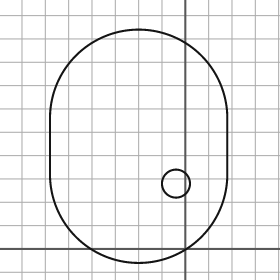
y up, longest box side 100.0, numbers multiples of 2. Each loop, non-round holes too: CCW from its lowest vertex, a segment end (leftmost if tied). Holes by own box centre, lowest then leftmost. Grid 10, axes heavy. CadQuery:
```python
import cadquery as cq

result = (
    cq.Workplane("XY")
    .moveTo(-58.0, 32.0)
    .threePointArc((-20.0, -6.0), (18.0, 32.0))
    .lineTo(18.0, 56.0)
    .threePointArc((-20.0, 94.0), (-58.0, 56.0))
    .close()
    .moveTo(-4.0, 28.0)
    .circle(6.0)
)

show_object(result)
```